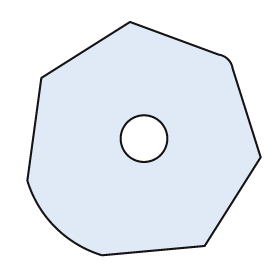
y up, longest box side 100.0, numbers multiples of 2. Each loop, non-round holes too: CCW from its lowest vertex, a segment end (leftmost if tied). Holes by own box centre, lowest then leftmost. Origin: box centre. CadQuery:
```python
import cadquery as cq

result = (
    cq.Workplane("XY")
    .moveTo(-18.0, -50.0)
    .lineTo(26.0, -46.0)
    .lineTo(50.0, -8.0)
    .lineTo(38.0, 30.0)
    .threePointArc((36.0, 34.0), (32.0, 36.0))
    .lineTo(-6.0, 50.0)
    .lineTo(-44.0, 26.0)
    .lineTo(-50.0, -18.0)
    .threePointArc((-38.0, -38.0), (-18.0, -50.0))
    .close()
    .moveTo(0.0, 0.0)
    .circle(10.0)
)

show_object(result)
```